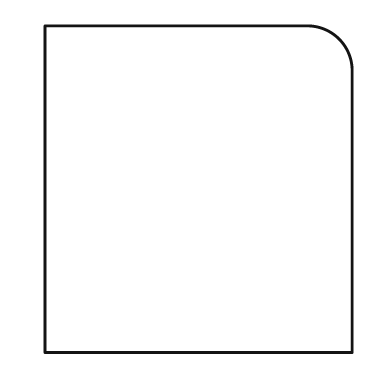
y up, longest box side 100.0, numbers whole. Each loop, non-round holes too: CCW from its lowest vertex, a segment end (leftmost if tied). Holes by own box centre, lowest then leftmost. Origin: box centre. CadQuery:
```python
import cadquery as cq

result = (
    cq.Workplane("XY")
    .moveTo(-47.0, -50.0)
    .lineTo(47.0, -50.0)
    .lineTo(47.0, 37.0)
    .threePointArc((43.0, 46.0), (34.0, 50.0))
    .lineTo(-47.0, 50.0)
    .close()
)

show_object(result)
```